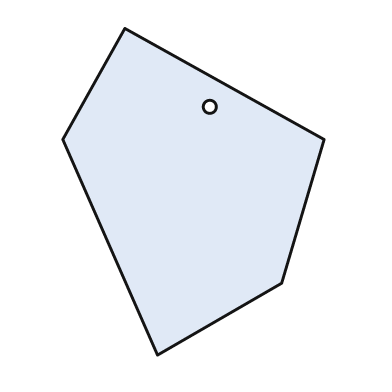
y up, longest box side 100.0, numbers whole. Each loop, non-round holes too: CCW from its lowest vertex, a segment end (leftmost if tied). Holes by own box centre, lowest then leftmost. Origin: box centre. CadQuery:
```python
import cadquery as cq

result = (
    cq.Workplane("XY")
    .moveTo(-11.0, -50.0)
    .lineTo(27.0, -28.0)
    .lineTo(40.0, 16.0)
    .lineTo(-21.0, 50.0)
    .lineTo(-40.0, 16.0)
    .close()
    .moveTo(5.0, 26.0)
    .circle(2.0)
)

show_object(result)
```